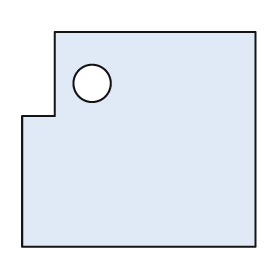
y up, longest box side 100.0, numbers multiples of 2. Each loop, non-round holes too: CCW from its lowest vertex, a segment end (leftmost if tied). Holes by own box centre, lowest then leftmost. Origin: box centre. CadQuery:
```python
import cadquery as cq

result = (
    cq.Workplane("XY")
    .moveTo(-50.0, -46.0)
    .lineTo(50.0, -46.0)
    .lineTo(50.0, 46.0)
    .lineTo(-36.0, 46.0)
    .lineTo(-36.0, 10.0)
    .lineTo(-50.0, 10.0)
    .close()
    .moveTo(-20.0, 24.0)
    .circle(8.0)
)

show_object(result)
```